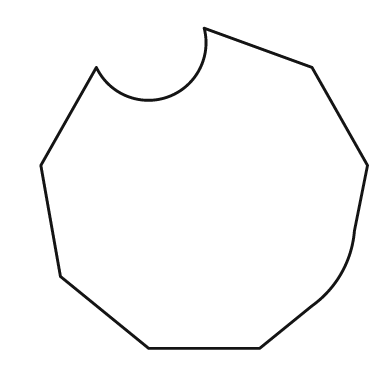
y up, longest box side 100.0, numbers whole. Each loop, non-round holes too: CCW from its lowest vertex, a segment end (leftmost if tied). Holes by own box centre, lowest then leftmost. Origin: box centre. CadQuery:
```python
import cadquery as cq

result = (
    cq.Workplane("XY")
    .moveTo(-17.0, -49.0)
    .lineTo(17.0, -49.0)
    .lineTo(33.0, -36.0)
    .threePointArc((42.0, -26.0), (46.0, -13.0))
    .lineTo(50.0, 7.0)
    .lineTo(33.0, 37.0)
    .lineTo(0.0, 49.0)
    .threePointArc((-11.0, 28.0), (-33.0, 37.0))
    .lineTo(-50.0, 7.0)
    .lineTo(-44.0, -27.0)
    .close()
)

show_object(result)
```